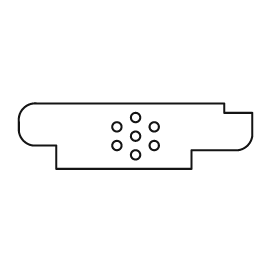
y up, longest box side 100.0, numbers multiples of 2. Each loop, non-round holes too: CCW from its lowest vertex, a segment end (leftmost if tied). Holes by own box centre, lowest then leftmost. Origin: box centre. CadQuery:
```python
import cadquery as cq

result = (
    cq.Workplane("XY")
    .moveTo(-34.0, -14.0)
    .lineTo(24.0, -14.0)
    .lineTo(24.0, -6.0)
    .lineTo(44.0, -6.0)
    .threePointArc((48.0, -4.0), (50.0, 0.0))
    .lineTo(50.0, 10.0)
    .lineTo(38.0, 10.0)
    .lineTo(38.0, 14.0)
    .lineTo(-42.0, 14.0)
    .threePointArc((-48.0, 12.0), (-50.0, 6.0))
    .lineTo(-50.0, 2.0)
    .threePointArc((-48.0, -2.0), (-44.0, -4.0))
    .lineTo(-34.0, -4.0)
    .close()
    .moveTo(0.0, -8.0)
    .circle(2.0)
    .moveTo(-8.0, -4.0)
    .circle(2.0)
    .moveTo(8.0, -4.0)
    .circle(2.0)
    .moveTo(0.0, 0.0)
    .circle(2.0)
    .moveTo(-8.0, 4.0)
    .circle(2.0)
    .moveTo(8.0, 4.0)
    .circle(2.0)
    .moveTo(0.0, 8.0)
    .circle(2.0)
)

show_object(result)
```